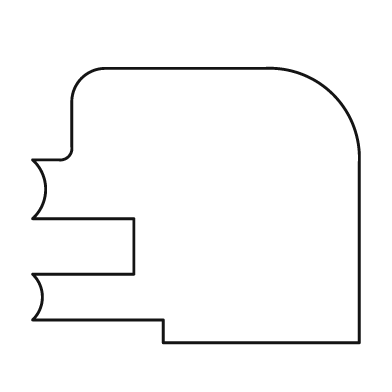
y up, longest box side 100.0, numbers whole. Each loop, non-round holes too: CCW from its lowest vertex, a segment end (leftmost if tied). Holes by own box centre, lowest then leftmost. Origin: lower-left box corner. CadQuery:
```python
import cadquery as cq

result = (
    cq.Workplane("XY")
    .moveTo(40.0, 0.0)
    .lineTo(100.0, 0.0)
    .lineTo(100.0, 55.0)
    .threePointArc((92.0, 76.0), (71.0, 84.0))
    .lineTo(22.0, 84.0)
    .threePointArc((15.0, 81.0), (12.0, 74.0))
    .lineTo(12.0, 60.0)
    .threePointArc((11.0, 57.0), (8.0, 56.0))
    .lineTo(0.0, 56.0)
    .threePointArc((4.0, 47.0), (0.0, 38.0))
    .lineTo(31.0, 38.0)
    .lineTo(31.0, 21.0)
    .lineTo(0.0, 21.0)
    .threePointArc((3.0, 14.0), (0.0, 7.0))
    .lineTo(40.0, 7.0)
    .close()
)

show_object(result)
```